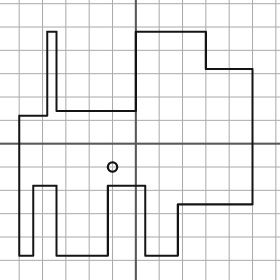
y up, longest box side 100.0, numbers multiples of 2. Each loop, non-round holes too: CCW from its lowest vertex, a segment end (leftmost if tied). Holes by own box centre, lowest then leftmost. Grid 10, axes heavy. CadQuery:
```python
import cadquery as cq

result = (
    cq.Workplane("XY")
    .moveTo(-50.0, -48.0)
    .lineTo(-44.0, -48.0)
    .lineTo(-44.0, -18.0)
    .lineTo(-34.0, -18.0)
    .lineTo(-34.0, -48.0)
    .lineTo(-12.0, -48.0)
    .lineTo(-12.0, -18.0)
    .lineTo(4.0, -18.0)
    .lineTo(4.0, -48.0)
    .lineTo(18.0, -48.0)
    .lineTo(18.0, -26.0)
    .lineTo(50.0, -26.0)
    .lineTo(50.0, 32.0)
    .lineTo(30.0, 32.0)
    .lineTo(30.0, 48.0)
    .lineTo(0.0, 48.0)
    .lineTo(0.0, 14.0)
    .lineTo(-34.0, 14.0)
    .lineTo(-34.0, 48.0)
    .lineTo(-38.0, 48.0)
    .lineTo(-38.0, 12.0)
    .lineTo(-50.0, 12.0)
    .close()
    .moveTo(-10.0, -10.0)
    .circle(2.0)
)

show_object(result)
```